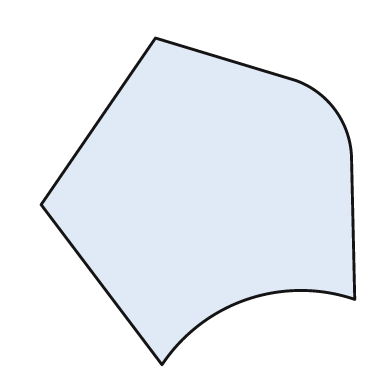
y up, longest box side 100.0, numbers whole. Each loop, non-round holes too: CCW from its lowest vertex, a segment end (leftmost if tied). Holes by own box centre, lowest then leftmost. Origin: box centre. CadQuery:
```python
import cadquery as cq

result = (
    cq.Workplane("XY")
    .moveTo(-11.0, -50.0)
    .threePointArc((15.0, -30.0), (48.0, -30.0))
    .lineTo(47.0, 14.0)
    .threePointArc((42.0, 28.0), (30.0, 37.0))
    .lineTo(-13.0, 50.0)
    .lineTo(-48.0, -1.0)
    .close()
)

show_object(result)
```